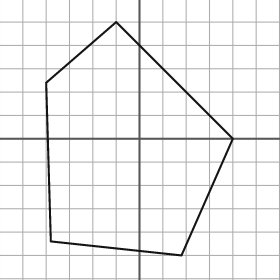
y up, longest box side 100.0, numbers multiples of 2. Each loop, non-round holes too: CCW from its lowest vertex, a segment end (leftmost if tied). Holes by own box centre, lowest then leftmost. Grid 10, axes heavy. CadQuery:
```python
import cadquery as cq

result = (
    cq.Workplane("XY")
    .moveTo(18.0, -50.0)
    .lineTo(40.0, 0.0)
    .lineTo(-10.0, 50.0)
    .lineTo(-40.0, 24.0)
    .lineTo(-38.0, -44.0)
    .close()
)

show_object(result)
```